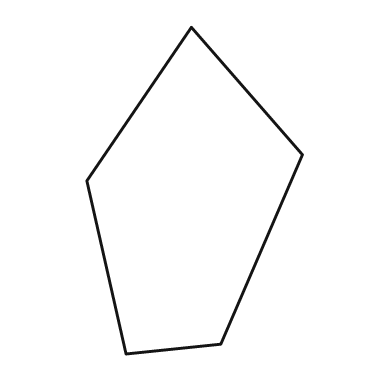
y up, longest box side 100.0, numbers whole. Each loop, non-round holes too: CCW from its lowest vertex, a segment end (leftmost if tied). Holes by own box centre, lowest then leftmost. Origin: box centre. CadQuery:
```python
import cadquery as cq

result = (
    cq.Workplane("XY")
    .moveTo(-21.0, -50.0)
    .lineTo(8.0, -47.0)
    .lineTo(33.0, 11.0)
    .lineTo(-1.0, 50.0)
    .lineTo(-33.0, 3.0)
    .close()
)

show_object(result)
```